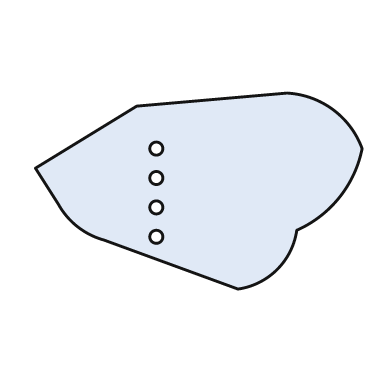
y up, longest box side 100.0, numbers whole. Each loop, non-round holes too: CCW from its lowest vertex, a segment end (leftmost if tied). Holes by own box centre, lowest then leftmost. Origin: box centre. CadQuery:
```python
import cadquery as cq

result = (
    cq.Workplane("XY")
    .moveTo(12.0, -30.0)
    .threePointArc((24.0, -24.0), (30.0, -12.0))
    .threePointArc((43.0, -2.0), (50.0, 13.0))
    .threePointArc((41.0, 25.0), (27.0, 30.0))
    .lineTo(-19.0, 26.0)
    .lineTo(-50.0, 7.0)
    .lineTo(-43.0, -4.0)
    .threePointArc((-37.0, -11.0), (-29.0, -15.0))
    .close()
    .moveTo(-13.0, -14.0)
    .circle(2.0)
    .moveTo(-13.0, -5.0)
    .circle(2.0)
    .moveTo(-13.0, 4.0)
    .circle(2.0)
    .moveTo(-13.0, 13.0)
    .circle(2.0)
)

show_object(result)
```